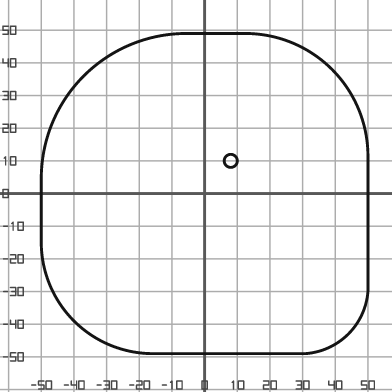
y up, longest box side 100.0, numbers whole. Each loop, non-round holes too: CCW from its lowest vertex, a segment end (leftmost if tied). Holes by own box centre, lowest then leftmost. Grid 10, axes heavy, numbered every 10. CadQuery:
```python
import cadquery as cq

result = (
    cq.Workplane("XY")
    .moveTo(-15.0, -49.0)
    .lineTo(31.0, -49.0)
    .threePointArc((44.0, -43.0), (50.0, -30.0))
    .lineTo(50.0, 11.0)
    .threePointArc((39.0, 38.0), (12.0, 49.0))
    .lineTo(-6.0, 49.0)
    .threePointArc((-37.0, 36.0), (-50.0, 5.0))
    .lineTo(-50.0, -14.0)
    .threePointArc((-40.0, -39.0), (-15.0, -49.0))
    .close()
    .moveTo(8.0, 10.0)
    .circle(2.0)
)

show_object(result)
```